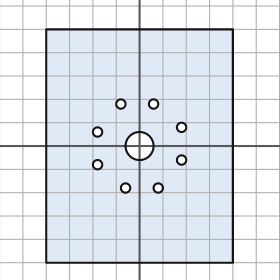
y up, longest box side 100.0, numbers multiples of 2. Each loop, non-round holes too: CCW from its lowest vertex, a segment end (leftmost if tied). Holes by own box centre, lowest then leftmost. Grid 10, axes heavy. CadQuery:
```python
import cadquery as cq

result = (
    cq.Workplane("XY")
    .moveTo(-40.0, -50.0)
    .lineTo(40.0, -50.0)
    .lineTo(40.0, 50.0)
    .lineTo(-40.0, 50.0)
    .close()
    .moveTo(-6.0, -18.0)
    .circle(2.0)
    .moveTo(8.0, -18.0)
    .circle(2.0)
    .moveTo(-18.0, -8.0)
    .circle(2.0)
    .moveTo(18.0, -6.0)
    .circle(2.0)
    .moveTo(0.0, 0.0)
    .circle(6.0)
    .moveTo(-18.0, 6.0)
    .circle(2.0)
    .moveTo(18.0, 8.0)
    .circle(2.0)
    .moveTo(-8.0, 18.0)
    .circle(2.0)
    .moveTo(6.0, 18.0)
    .circle(2.0)
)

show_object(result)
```